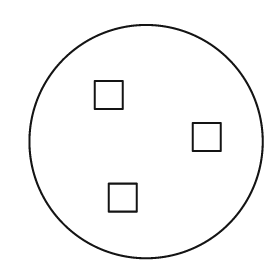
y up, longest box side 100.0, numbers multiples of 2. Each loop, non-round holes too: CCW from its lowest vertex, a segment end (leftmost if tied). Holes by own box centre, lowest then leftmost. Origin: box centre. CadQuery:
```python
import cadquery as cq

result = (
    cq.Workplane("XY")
    .moveTo(0.0, 0.0)
    .circle(50.0)
    .moveTo(-16.0, -30.0)
    .lineTo(-4.0, -30.0)
    .lineTo(-4.0, -18.0)
    .lineTo(-16.0, -18.0)
    .close()
    .moveTo(20.0, -4.0)
    .lineTo(32.0, -4.0)
    .lineTo(32.0, 8.0)
    .lineTo(20.0, 8.0)
    .close()
    .moveTo(-22.0, 14.0)
    .lineTo(-10.0, 14.0)
    .lineTo(-10.0, 26.0)
    .lineTo(-22.0, 26.0)
    .close()
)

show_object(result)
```